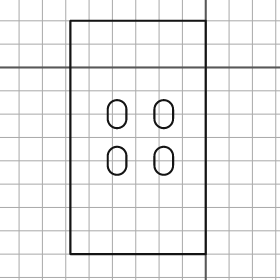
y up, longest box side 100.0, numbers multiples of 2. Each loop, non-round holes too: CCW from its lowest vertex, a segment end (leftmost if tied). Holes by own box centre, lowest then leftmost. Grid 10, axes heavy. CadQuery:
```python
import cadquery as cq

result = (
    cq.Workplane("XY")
    .moveTo(-58.0, -80.0)
    .lineTo(0.0, -80.0)
    .lineTo(0.0, 20.0)
    .lineTo(-58.0, 20.0)
    .close()
    .moveTo(-42.0, -42.0)
    .threePointArc((-38.0, -46.0), (-34.0, -42.0))
    .lineTo(-34.0, -38.0)
    .threePointArc((-38.0, -34.0), (-42.0, -38.0))
    .close()
    .moveTo(-22.0, -42.0)
    .threePointArc((-18.0, -46.0), (-14.0, -42.0))
    .lineTo(-14.0, -38.0)
    .threePointArc((-18.0, -34.0), (-22.0, -38.0))
    .close()
    .moveTo(-42.0, -22.0)
    .threePointArc((-38.0, -26.0), (-34.0, -22.0))
    .lineTo(-34.0, -18.0)
    .threePointArc((-38.0, -14.0), (-42.0, -18.0))
    .close()
    .moveTo(-22.0, -22.0)
    .threePointArc((-18.0, -26.0), (-14.0, -22.0))
    .lineTo(-14.0, -18.0)
    .threePointArc((-18.0, -14.0), (-22.0, -18.0))
    .close()
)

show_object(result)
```